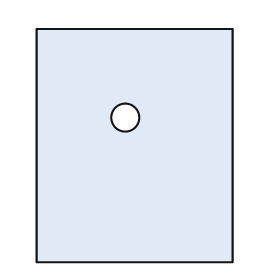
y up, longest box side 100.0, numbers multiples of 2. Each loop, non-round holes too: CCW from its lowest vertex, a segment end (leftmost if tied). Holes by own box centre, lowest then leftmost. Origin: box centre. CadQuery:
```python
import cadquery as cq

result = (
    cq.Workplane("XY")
    .moveTo(-42.0, -50.0)
    .lineTo(42.0, -50.0)
    .lineTo(42.0, 50.0)
    .lineTo(-42.0, 50.0)
    .close()
    .moveTo(-4.0, 12.0)
    .circle(6.0)
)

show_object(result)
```